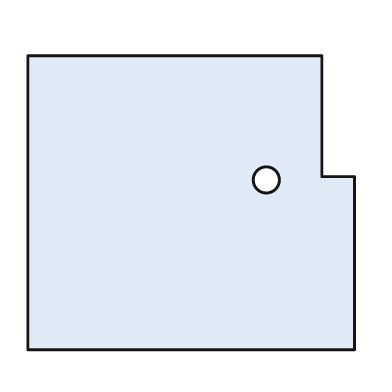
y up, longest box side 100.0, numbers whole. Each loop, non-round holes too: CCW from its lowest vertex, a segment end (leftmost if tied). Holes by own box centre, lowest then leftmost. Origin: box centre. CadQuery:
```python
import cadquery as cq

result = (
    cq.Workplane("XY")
    .moveTo(-50.0, -45.0)
    .lineTo(50.0, -45.0)
    .lineTo(50.0, 8.0)
    .lineTo(40.0, 8.0)
    .lineTo(40.0, 45.0)
    .lineTo(-50.0, 45.0)
    .close()
    .moveTo(23.0, 7.0)
    .circle(4.0)
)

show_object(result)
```